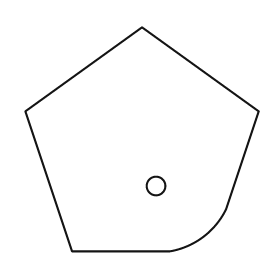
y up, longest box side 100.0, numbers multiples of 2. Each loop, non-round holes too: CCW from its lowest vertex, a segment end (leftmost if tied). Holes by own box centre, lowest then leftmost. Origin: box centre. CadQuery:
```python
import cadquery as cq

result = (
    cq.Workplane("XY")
    .moveTo(-30.0, -48.0)
    .lineTo(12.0, -48.0)
    .threePointArc((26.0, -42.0), (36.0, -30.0))
    .lineTo(50.0, 12.0)
    .lineTo(0.0, 48.0)
    .lineTo(-50.0, 12.0)
    .close()
    .moveTo(6.0, -20.0)
    .circle(4.0)
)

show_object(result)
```